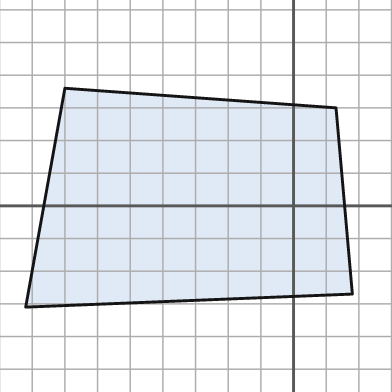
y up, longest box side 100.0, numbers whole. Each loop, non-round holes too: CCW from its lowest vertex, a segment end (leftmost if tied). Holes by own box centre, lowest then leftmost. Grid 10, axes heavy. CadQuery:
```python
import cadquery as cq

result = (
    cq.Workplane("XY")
    .moveTo(-82.0, -31.0)
    .lineTo(18.0, -27.0)
    .lineTo(13.0, 30.0)
    .lineTo(-70.0, 36.0)
    .close()
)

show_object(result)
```